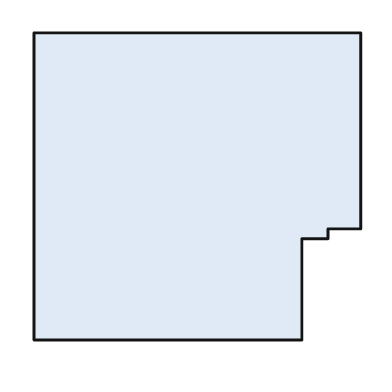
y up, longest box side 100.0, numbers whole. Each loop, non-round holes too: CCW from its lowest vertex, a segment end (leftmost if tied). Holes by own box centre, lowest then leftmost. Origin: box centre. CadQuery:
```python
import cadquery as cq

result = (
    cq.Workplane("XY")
    .moveTo(-50.0, -47.0)
    .lineTo(32.0, -47.0)
    .lineTo(32.0, -16.0)
    .lineTo(40.0, -16.0)
    .lineTo(40.0, -13.0)
    .lineTo(50.0, -13.0)
    .lineTo(50.0, 47.0)
    .lineTo(-50.0, 47.0)
    .close()
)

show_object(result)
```